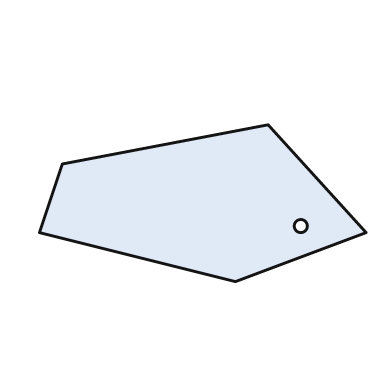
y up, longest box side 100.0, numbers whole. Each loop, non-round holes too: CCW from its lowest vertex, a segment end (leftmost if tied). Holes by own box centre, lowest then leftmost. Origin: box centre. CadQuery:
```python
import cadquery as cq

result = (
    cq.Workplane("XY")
    .moveTo(10.0, -24.0)
    .lineTo(50.0, -9.0)
    .lineTo(20.0, 24.0)
    .lineTo(-43.0, 12.0)
    .lineTo(-50.0, -9.0)
    .close()
    .moveTo(30.0, -7.0)
    .circle(2.0)
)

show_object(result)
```